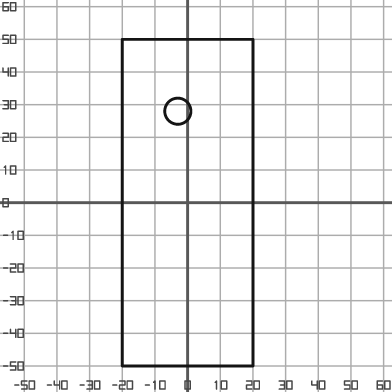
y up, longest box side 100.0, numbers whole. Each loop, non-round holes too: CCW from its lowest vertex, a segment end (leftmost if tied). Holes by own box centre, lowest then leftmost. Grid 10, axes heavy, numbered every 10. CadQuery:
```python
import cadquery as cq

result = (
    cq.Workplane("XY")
    .moveTo(-20.0, -50.0)
    .lineTo(20.0, -50.0)
    .lineTo(20.0, 50.0)
    .lineTo(-20.0, 50.0)
    .close()
    .moveTo(-3.0, 28.0)
    .circle(4.0)
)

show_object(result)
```